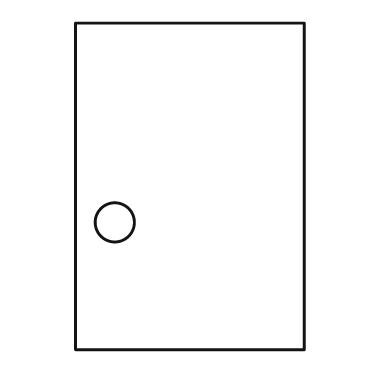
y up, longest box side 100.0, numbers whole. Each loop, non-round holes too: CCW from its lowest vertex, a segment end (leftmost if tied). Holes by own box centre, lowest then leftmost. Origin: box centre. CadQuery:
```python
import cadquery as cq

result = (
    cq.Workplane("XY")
    .moveTo(-35.0, -50.0)
    .lineTo(35.0, -50.0)
    .lineTo(35.0, 50.0)
    .lineTo(-35.0, 50.0)
    .close()
    .moveTo(-23.0, -11.0)
    .circle(6.0)
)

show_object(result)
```